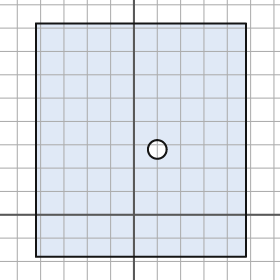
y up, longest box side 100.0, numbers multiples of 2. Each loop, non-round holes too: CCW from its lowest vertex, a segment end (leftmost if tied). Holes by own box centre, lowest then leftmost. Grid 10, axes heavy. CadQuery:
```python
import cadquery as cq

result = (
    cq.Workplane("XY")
    .moveTo(-42.0, -18.0)
    .lineTo(48.0, -18.0)
    .lineTo(48.0, 82.0)
    .lineTo(-42.0, 82.0)
    .close()
    .moveTo(10.0, 28.0)
    .circle(4.0)
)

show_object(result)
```